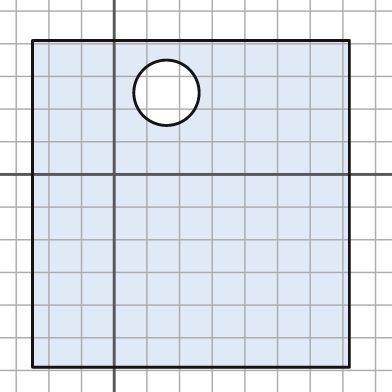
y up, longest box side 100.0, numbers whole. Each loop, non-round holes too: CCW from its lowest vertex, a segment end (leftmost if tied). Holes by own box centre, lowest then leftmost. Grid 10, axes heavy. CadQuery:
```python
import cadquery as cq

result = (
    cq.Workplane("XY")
    .moveTo(-25.0, -59.0)
    .lineTo(72.0, -59.0)
    .lineTo(72.0, 41.0)
    .lineTo(-25.0, 41.0)
    .close()
    .moveTo(16.0, 25.0)
    .circle(10.0)
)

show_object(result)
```